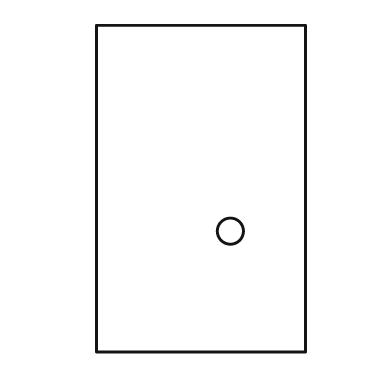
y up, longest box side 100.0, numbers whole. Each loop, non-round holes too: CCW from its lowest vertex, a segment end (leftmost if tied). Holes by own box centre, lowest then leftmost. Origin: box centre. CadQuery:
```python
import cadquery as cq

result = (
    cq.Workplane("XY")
    .moveTo(-32.0, -50.0)
    .lineTo(32.0, -50.0)
    .lineTo(32.0, 50.0)
    .lineTo(-32.0, 50.0)
    .close()
    .moveTo(9.0, -13.0)
    .circle(4.0)
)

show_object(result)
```